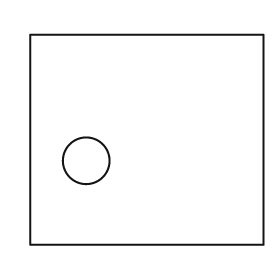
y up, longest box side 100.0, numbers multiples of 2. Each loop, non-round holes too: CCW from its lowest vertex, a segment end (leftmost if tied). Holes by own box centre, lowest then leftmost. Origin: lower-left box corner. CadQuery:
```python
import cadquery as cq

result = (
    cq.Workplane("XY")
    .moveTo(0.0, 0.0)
    .lineTo(100.0, 0.0)
    .lineTo(100.0, 90.0)
    .lineTo(0.0, 90.0)
    .close()
    .moveTo(24.0, 36.0)
    .circle(10.0)
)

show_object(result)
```